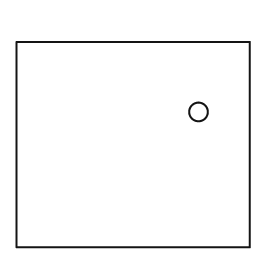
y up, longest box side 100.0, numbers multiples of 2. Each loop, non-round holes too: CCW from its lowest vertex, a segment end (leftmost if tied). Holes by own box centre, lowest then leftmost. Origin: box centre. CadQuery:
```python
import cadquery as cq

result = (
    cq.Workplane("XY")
    .moveTo(-50.0, -44.0)
    .lineTo(50.0, -44.0)
    .lineTo(50.0, 44.0)
    .lineTo(-50.0, 44.0)
    .close()
    .moveTo(28.0, 14.0)
    .circle(4.0)
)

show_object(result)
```